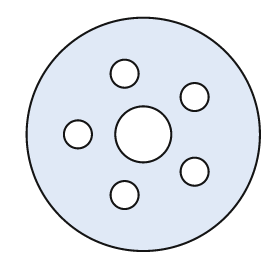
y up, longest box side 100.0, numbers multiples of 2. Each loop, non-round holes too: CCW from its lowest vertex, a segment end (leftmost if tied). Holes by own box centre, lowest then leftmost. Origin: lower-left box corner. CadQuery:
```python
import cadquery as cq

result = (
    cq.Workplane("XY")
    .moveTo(50.0, 50.0)
    .circle(50.0)
    .moveTo(42.0, 24.0)
    .circle(6.0)
    .moveTo(72.0, 34.0)
    .circle(6.0)
    .moveTo(22.0, 50.0)
    .circle(6.0)
    .moveTo(50.0, 50.0)
    .circle(12.0)
    .moveTo(72.0, 66.0)
    .circle(6.0)
    .moveTo(42.0, 76.0)
    .circle(6.0)
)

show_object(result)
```